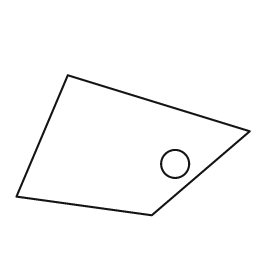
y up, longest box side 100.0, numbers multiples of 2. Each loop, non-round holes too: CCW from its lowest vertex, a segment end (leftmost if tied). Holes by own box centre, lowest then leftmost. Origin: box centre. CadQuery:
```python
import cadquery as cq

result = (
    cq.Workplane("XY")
    .moveTo(8.0, -30.0)
    .lineTo(50.0, 6.0)
    .lineTo(-28.0, 30.0)
    .lineTo(-50.0, -22.0)
    .close()
    .moveTo(18.0, -8.0)
    .circle(6.0)
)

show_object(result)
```